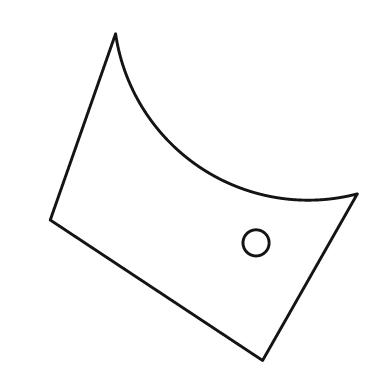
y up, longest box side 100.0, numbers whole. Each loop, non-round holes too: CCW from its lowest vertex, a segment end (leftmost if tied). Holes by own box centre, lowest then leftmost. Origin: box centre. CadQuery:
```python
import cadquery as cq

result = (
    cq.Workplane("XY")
    .moveTo(18.0, -50.0)
    .lineTo(47.0, 1.0)
    .threePointArc((-1.0, 9.0), (-27.0, 50.0))
    .lineTo(-47.0, -7.0)
    .close()
    .moveTo(16.0, -14.0)
    .circle(4.0)
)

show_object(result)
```